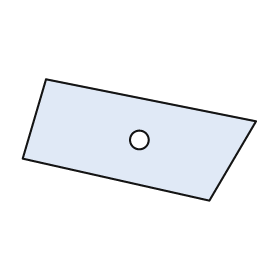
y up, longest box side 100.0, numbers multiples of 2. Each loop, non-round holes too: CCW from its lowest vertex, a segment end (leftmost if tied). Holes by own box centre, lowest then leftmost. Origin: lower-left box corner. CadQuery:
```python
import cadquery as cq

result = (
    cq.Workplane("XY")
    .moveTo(80.0, 0.0)
    .lineTo(100.0, 34.0)
    .lineTo(10.0, 52.0)
    .lineTo(0.0, 18.0)
    .close()
    .moveTo(50.0, 26.0)
    .circle(4.0)
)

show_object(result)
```